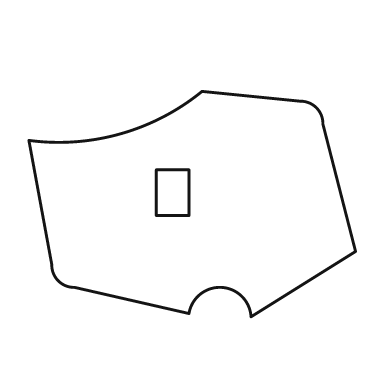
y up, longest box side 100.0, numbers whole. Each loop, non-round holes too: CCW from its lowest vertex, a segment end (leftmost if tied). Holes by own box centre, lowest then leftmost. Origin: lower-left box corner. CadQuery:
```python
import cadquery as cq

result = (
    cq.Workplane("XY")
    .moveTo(68.0, 0.0)
    .lineTo(100.0, 20.0)
    .lineTo(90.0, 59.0)
    .threePointArc((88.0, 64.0), (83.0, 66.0))
    .lineTo(53.0, 69.0)
    .threePointArc((28.0, 56.0), (0.0, 54.0))
    .lineTo(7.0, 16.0)
    .threePointArc((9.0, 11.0), (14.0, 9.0))
    .lineTo(49.0, 1.0)
    .threePointArc((59.0, 9.0), (68.0, 0.0))
    .close()
    .moveTo(39.0, 31.0)
    .lineTo(49.0, 31.0)
    .lineTo(49.0, 45.0)
    .lineTo(39.0, 45.0)
    .close()
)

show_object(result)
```